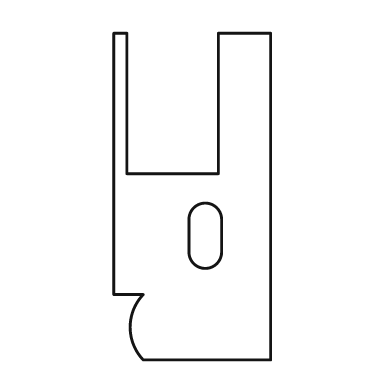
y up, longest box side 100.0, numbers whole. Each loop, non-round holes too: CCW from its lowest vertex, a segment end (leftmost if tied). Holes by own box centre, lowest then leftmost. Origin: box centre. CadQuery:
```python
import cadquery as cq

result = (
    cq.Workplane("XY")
    .moveTo(-15.0, -50.0)
    .lineTo(24.0, -50.0)
    .lineTo(24.0, 50.0)
    .lineTo(8.0, 50.0)
    .lineTo(8.0, 7.0)
    .lineTo(-20.0, 7.0)
    .lineTo(-20.0, 50.0)
    .lineTo(-24.0, 50.0)
    .lineTo(-24.0, -30.0)
    .lineTo(-15.0, -30.0)
    .threePointArc((-19.0, -40.0), (-15.0, -50.0))
    .close()
    .moveTo(-1.0, -17.0)
    .threePointArc((4.0, -22.0), (9.0, -17.0))
    .lineTo(9.0, -7.0)
    .threePointArc((4.0, -2.0), (-1.0, -7.0))
    .close()
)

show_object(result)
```